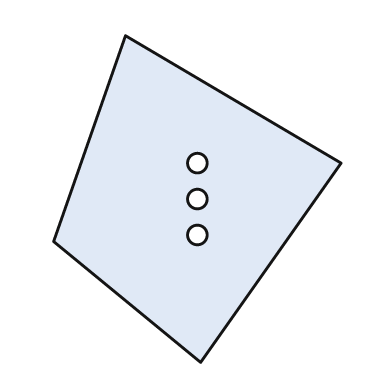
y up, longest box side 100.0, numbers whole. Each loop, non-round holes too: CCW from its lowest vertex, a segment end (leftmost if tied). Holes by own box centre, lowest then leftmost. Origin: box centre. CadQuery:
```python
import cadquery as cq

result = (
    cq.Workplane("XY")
    .moveTo(1.0, -50.0)
    .lineTo(44.0, 11.0)
    .lineTo(-22.0, 50.0)
    .lineTo(-44.0, -13.0)
    .close()
    .moveTo(0.0, -11.0)
    .circle(3.0)
    .moveTo(0.0, 0.0)
    .circle(3.0)
    .moveTo(0.0, 11.0)
    .circle(3.0)
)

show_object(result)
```